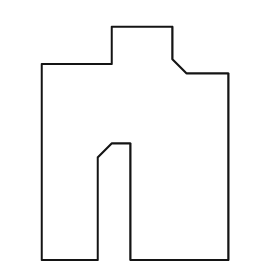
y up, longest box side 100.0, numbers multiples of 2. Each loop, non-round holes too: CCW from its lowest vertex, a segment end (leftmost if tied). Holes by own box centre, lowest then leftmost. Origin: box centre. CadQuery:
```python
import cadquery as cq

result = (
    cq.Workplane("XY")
    .moveTo(-40.0, -50.0)
    .lineTo(-16.0, -50.0)
    .lineTo(-16.0, -6.0)
    .lineTo(-10.0, 0.0)
    .lineTo(-2.0, 0.0)
    .lineTo(-2.0, -50.0)
    .lineTo(40.0, -50.0)
    .lineTo(40.0, 30.0)
    .lineTo(22.0, 30.0)
    .lineTo(16.0, 36.0)
    .lineTo(16.0, 50.0)
    .lineTo(-10.0, 50.0)
    .lineTo(-10.0, 34.0)
    .lineTo(-40.0, 34.0)
    .close()
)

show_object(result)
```